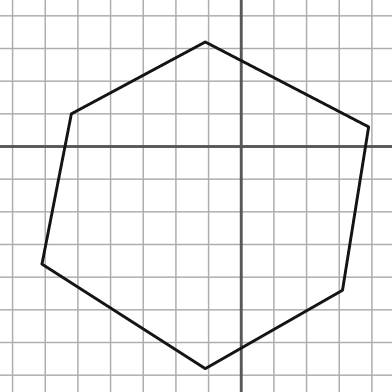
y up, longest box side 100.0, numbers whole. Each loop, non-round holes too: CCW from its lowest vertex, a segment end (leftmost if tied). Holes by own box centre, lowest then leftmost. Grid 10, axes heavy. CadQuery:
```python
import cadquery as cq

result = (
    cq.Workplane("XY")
    .moveTo(-11.0, -68.0)
    .lineTo(31.0, -44.0)
    .lineTo(39.0, 6.0)
    .lineTo(-11.0, 32.0)
    .lineTo(-52.0, 10.0)
    .lineTo(-61.0, -36.0)
    .close()
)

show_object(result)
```